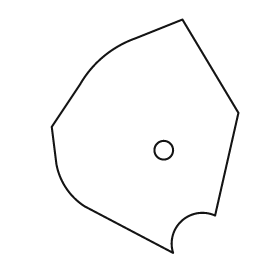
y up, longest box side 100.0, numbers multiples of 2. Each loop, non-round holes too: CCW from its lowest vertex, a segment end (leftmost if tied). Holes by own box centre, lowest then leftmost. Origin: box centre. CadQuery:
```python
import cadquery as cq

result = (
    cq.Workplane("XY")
    .moveTo(12.0, -50.0)
    .threePointArc((16.0, -36.0), (30.0, -34.0))
    .lineTo(40.0, 10.0)
    .lineTo(16.0, 50.0)
    .lineTo(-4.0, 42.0)
    .threePointArc((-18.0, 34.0), (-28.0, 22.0))
    .lineTo(-40.0, 4.0)
    .lineTo(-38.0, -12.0)
    .threePointArc((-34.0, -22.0), (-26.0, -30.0))
    .close()
    .moveTo(8.0, -6.0)
    .circle(4.0)
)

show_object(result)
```